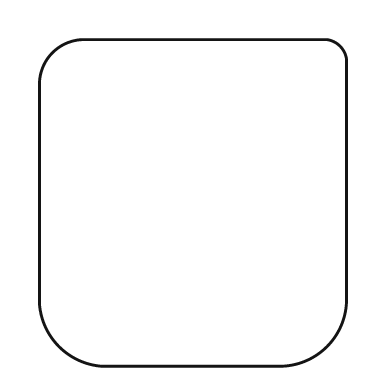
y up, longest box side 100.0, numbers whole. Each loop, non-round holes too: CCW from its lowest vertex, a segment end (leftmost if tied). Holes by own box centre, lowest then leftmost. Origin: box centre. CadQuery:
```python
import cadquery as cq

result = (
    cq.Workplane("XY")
    .moveTo(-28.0, -50.0)
    .lineTo(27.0, -50.0)
    .threePointArc((41.0, -44.0), (47.0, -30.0))
    .lineTo(47.0, 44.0)
    .threePointArc((45.0, 48.0), (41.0, 50.0))
    .lineTo(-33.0, 50.0)
    .threePointArc((-43.0, 46.0), (-47.0, 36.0))
    .lineTo(-47.0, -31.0)
    .threePointArc((-41.0, -44.0), (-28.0, -50.0))
    .close()
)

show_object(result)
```